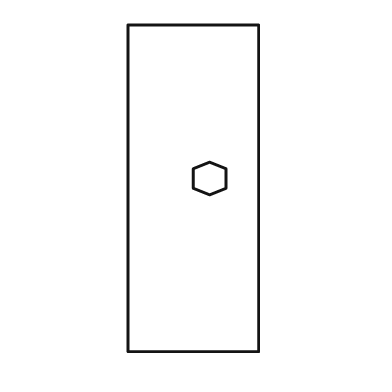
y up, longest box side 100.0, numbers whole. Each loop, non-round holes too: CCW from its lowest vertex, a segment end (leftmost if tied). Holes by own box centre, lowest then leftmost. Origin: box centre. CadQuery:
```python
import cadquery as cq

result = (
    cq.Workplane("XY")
    .moveTo(-20.0, -50.0)
    .lineTo(20.0, -50.0)
    .lineTo(20.0, 50.0)
    .lineTo(-20.0, 50.0)
    .close()
    .moveTo(5.0, -2.0)
    .lineTo(10.0, 0.0)
    .lineTo(10.0, 6.0)
    .lineTo(5.0, 8.0)
    .lineTo(0.0, 6.0)
    .lineTo(0.0, 0.0)
    .close()
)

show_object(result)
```